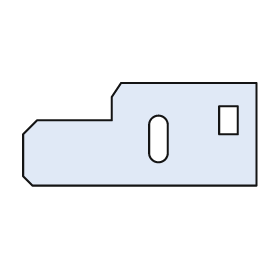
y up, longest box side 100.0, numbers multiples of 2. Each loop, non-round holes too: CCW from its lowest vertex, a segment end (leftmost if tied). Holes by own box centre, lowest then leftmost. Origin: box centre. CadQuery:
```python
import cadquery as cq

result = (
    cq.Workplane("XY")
    .moveTo(-46.0, -22.0)
    .lineTo(50.0, -22.0)
    .lineTo(50.0, 22.0)
    .lineTo(-8.0, 22.0)
    .lineTo(-12.0, 16.0)
    .lineTo(-12.0, 6.0)
    .lineTo(-44.0, 6.0)
    .lineTo(-50.0, 0.0)
    .lineTo(-50.0, -18.0)
    .close()
    .moveTo(4.0, -8.0)
    .threePointArc((8.0, -12.0), (12.0, -8.0))
    .lineTo(12.0, 4.0)
    .threePointArc((8.0, 8.0), (4.0, 4.0))
    .close()
    .moveTo(34.0, 0.0)
    .lineTo(42.0, 0.0)
    .lineTo(42.0, 12.0)
    .lineTo(34.0, 12.0)
    .close()
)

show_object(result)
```